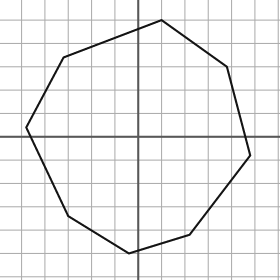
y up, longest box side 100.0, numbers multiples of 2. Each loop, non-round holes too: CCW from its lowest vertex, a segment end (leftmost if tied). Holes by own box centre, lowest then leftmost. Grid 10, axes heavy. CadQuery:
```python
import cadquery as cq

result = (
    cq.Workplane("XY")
    .moveTo(-4.0, -50.0)
    .lineTo(22.0, -42.0)
    .lineTo(48.0, -8.0)
    .lineTo(38.0, 30.0)
    .lineTo(10.0, 50.0)
    .lineTo(-32.0, 34.0)
    .lineTo(-48.0, 4.0)
    .lineTo(-30.0, -34.0)
    .close()
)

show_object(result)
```